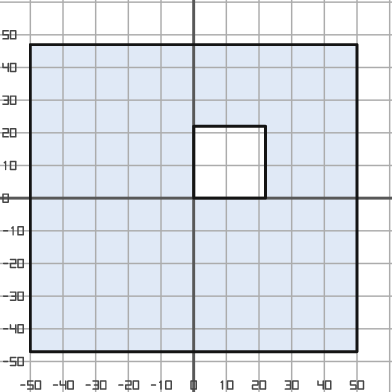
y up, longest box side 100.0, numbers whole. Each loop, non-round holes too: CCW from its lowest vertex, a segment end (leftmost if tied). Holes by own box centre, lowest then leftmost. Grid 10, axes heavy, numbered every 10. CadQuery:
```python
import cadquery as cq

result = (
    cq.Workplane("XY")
    .moveTo(-50.0, -47.0)
    .lineTo(50.0, -47.0)
    .lineTo(50.0, 47.0)
    .lineTo(-50.0, 47.0)
    .close()
    .moveTo(0.0, 0.0)
    .lineTo(22.0, 0.0)
    .lineTo(22.0, 22.0)
    .lineTo(0.0, 22.0)
    .close()
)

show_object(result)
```